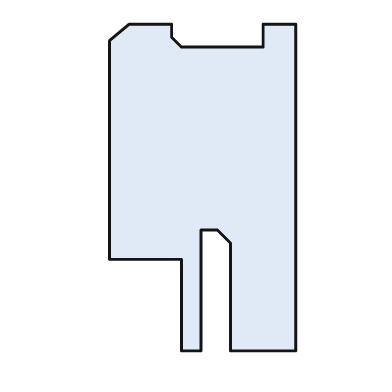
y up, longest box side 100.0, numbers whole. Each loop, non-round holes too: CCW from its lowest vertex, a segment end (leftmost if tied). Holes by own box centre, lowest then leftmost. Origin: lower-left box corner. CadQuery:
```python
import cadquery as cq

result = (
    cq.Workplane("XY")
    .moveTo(22.0, 0.0)
    .lineTo(28.0, 0.0)
    .lineTo(28.0, 37.0)
    .lineTo(33.0, 37.0)
    .lineTo(37.0, 33.0)
    .lineTo(37.0, 0.0)
    .lineTo(57.0, 0.0)
    .lineTo(57.0, 100.0)
    .lineTo(47.0, 100.0)
    .lineTo(47.0, 93.0)
    .lineTo(22.0, 93.0)
    .lineTo(19.0, 96.0)
    .lineTo(19.0, 100.0)
    .lineTo(6.0, 100.0)
    .lineTo(0.0, 95.0)
    .lineTo(0.0, 28.0)
    .lineTo(22.0, 28.0)
    .close()
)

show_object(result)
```